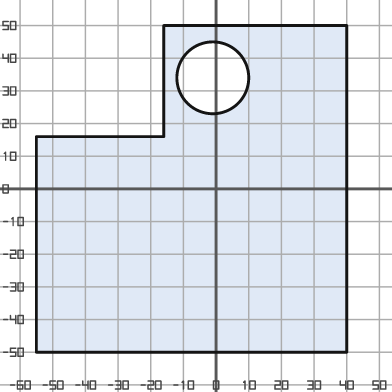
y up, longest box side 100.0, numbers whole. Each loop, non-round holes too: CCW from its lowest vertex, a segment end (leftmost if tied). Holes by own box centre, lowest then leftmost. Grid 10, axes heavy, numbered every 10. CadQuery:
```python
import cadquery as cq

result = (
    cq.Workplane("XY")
    .moveTo(-55.0, -50.0)
    .lineTo(40.0, -50.0)
    .lineTo(40.0, 50.0)
    .lineTo(-16.0, 50.0)
    .lineTo(-16.0, 16.0)
    .lineTo(-55.0, 16.0)
    .close()
    .moveTo(-1.0, 34.0)
    .circle(11.0)
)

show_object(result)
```